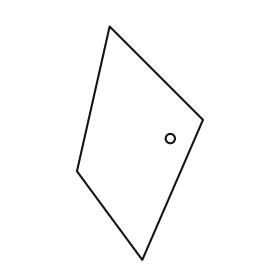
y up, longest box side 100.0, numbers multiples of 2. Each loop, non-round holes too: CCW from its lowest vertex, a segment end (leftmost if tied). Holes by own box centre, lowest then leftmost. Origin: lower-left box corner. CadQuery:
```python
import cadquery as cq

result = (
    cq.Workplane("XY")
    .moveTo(28.0, 0.0)
    .lineTo(54.0, 60.0)
    .lineTo(14.0, 100.0)
    .lineTo(0.0, 38.0)
    .close()
    .moveTo(40.0, 52.0)
    .circle(2.0)
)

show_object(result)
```